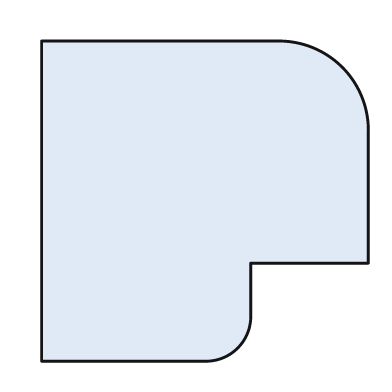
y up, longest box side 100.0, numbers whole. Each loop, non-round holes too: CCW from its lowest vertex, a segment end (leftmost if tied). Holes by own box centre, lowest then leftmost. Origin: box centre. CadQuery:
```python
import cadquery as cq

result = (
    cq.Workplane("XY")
    .moveTo(-50.0, -49.0)
    .lineTo(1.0, -49.0)
    .threePointArc((10.0, -45.0), (14.0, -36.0))
    .lineTo(14.0, -19.0)
    .lineTo(50.0, -19.0)
    .lineTo(50.0, 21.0)
    .threePointArc((42.0, 41.0), (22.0, 49.0))
    .lineTo(-50.0, 49.0)
    .close()
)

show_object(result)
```